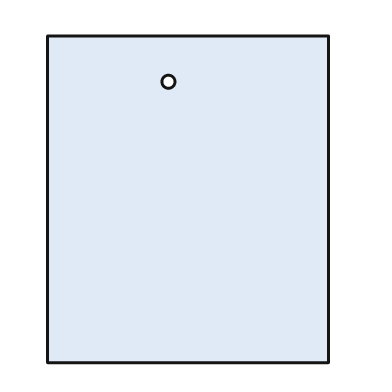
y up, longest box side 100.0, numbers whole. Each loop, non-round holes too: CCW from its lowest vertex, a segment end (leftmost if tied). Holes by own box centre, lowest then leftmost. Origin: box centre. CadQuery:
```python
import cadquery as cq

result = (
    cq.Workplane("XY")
    .moveTo(-43.0, -50.0)
    .lineTo(43.0, -50.0)
    .lineTo(43.0, 50.0)
    .lineTo(-43.0, 50.0)
    .close()
    .moveTo(-6.0, 36.0)
    .circle(2.0)
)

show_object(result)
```